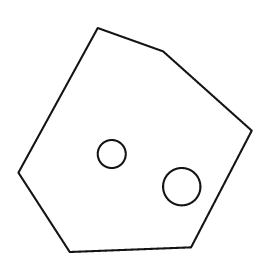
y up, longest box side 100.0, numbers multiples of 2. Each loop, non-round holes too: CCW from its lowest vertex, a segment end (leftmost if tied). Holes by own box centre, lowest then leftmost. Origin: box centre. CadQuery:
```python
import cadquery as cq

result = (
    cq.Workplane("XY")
    .moveTo(-28.0, -48.0)
    .lineTo(24.0, -46.0)
    .lineTo(50.0, 4.0)
    .lineTo(12.0, 38.0)
    .lineTo(-16.0, 48.0)
    .lineTo(-50.0, -14.0)
    .close()
    .moveTo(20.0, -20.0)
    .circle(8.0)
    .moveTo(-10.0, -6.0)
    .circle(6.0)
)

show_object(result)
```